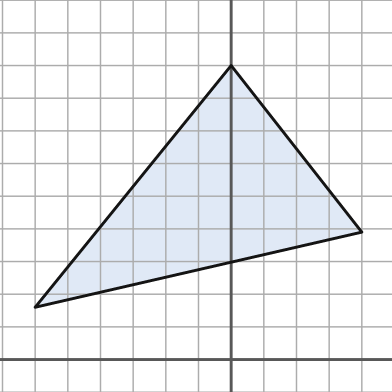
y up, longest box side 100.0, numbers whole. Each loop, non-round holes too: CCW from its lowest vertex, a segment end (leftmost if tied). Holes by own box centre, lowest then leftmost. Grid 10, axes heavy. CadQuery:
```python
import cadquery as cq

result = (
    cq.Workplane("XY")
    .moveTo(-60.0, 16.0)
    .lineTo(40.0, 39.0)
    .lineTo(0.0, 90.0)
    .close()
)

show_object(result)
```